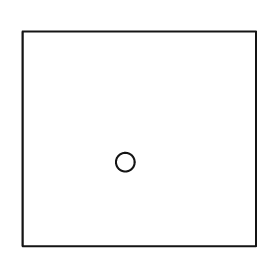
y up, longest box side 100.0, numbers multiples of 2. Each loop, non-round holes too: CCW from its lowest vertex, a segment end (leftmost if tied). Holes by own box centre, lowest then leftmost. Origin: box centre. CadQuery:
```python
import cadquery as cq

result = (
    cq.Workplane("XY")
    .moveTo(-50.0, -46.0)
    .lineTo(50.0, -46.0)
    .lineTo(50.0, 46.0)
    .lineTo(-50.0, 46.0)
    .close()
    .moveTo(-6.0, -10.0)
    .circle(4.0)
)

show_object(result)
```